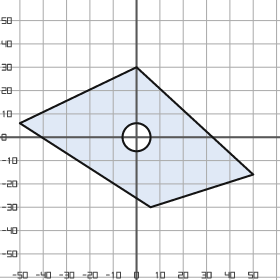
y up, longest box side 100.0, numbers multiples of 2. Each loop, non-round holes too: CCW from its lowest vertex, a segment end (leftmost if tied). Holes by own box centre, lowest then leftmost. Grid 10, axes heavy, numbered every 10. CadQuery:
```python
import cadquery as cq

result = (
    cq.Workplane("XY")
    .moveTo(6.0, -30.0)
    .lineTo(50.0, -16.0)
    .lineTo(0.0, 30.0)
    .lineTo(-50.0, 6.0)
    .close()
    .moveTo(0.0, 0.0)
    .circle(6.0)
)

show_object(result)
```